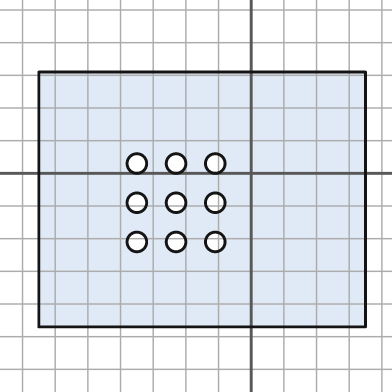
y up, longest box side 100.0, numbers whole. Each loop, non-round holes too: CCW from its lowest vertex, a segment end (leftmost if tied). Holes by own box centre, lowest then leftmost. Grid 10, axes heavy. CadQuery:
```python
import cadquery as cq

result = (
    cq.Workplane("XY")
    .moveTo(-65.0, -47.0)
    .lineTo(35.0, -47.0)
    .lineTo(35.0, 31.0)
    .lineTo(-65.0, 31.0)
    .close()
    .moveTo(-35.0, -21.0)
    .circle(3.0)
    .moveTo(-23.0, -21.0)
    .circle(3.0)
    .moveTo(-11.0, -21.0)
    .circle(3.0)
    .moveTo(-35.0, -9.0)
    .circle(3.0)
    .moveTo(-23.0, -9.0)
    .circle(3.0)
    .moveTo(-11.0, -9.0)
    .circle(3.0)
    .moveTo(-35.0, 3.0)
    .circle(3.0)
    .moveTo(-23.0, 3.0)
    .circle(3.0)
    .moveTo(-11.0, 3.0)
    .circle(3.0)
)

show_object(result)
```